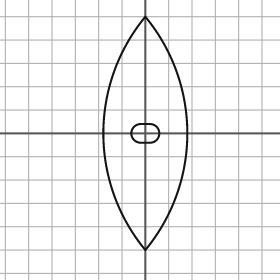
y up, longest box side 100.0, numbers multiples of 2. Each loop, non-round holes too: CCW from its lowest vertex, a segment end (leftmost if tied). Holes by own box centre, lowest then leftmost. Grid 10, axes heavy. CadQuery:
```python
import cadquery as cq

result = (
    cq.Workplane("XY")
    .moveTo(0.0, -50.0)
    .threePointArc((18.0, 0.0), (0.0, 50.0))
    .threePointArc((-18.0, 0.0), (0.0, -50.0))
    .close()
    .moveTo(-2.0, -4.0)
    .lineTo(2.0, -4.0)
    .threePointArc((6.0, 0.0), (2.0, 4.0))
    .lineTo(-2.0, 4.0)
    .threePointArc((-6.0, 0.0), (-2.0, -4.0))
    .close()
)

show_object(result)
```